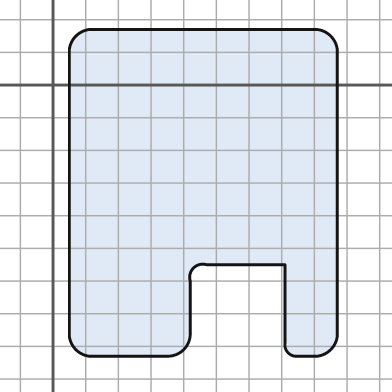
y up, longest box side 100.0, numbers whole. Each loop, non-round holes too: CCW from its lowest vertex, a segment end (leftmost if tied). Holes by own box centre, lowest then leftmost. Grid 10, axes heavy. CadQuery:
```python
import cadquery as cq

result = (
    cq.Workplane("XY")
    .moveTo(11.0, -83.0)
    .lineTo(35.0, -83.0)
    .threePointArc((40.0, -81.0), (42.0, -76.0))
    .lineTo(42.0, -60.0)
    .threePointArc((43.0, -56.0), (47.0, -55.0))
    .lineTo(71.0, -55.0)
    .lineTo(71.0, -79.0)
    .threePointArc((72.0, -82.0), (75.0, -83.0))
    .lineTo(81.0, -83.0)
    .threePointArc((85.0, -81.0), (87.0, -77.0))
    .lineTo(87.0, 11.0)
    .threePointArc((85.0, 15.0), (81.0, 17.0))
    .lineTo(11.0, 17.0)
    .threePointArc((7.0, 15.0), (5.0, 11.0))
    .lineTo(5.0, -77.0)
    .threePointArc((7.0, -81.0), (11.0, -83.0))
    .close()
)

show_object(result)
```